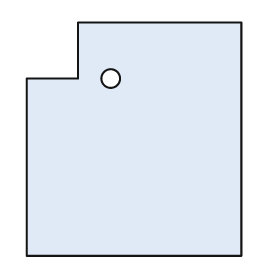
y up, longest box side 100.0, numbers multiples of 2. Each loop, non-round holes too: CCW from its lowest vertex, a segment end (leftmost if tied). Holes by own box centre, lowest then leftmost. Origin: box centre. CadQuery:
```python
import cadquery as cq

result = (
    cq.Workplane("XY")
    .moveTo(-46.0, -50.0)
    .lineTo(46.0, -50.0)
    .lineTo(46.0, 50.0)
    .lineTo(-24.0, 50.0)
    .lineTo(-24.0, 26.0)
    .lineTo(-46.0, 26.0)
    .close()
    .moveTo(-10.0, 26.0)
    .circle(4.0)
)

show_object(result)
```